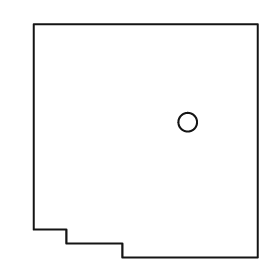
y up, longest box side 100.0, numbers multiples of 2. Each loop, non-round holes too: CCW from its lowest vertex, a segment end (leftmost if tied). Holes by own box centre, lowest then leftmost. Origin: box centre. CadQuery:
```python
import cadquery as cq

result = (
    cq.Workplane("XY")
    .moveTo(-10.0, -50.0)
    .lineTo(48.0, -50.0)
    .lineTo(48.0, 50.0)
    .lineTo(-48.0, 50.0)
    .lineTo(-48.0, -38.0)
    .lineTo(-34.0, -38.0)
    .lineTo(-34.0, -44.0)
    .lineTo(-10.0, -44.0)
    .close()
    .moveTo(18.0, 8.0)
    .circle(4.0)
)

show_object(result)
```